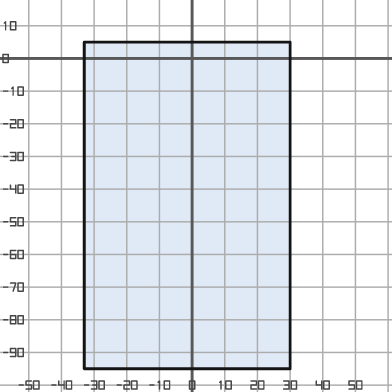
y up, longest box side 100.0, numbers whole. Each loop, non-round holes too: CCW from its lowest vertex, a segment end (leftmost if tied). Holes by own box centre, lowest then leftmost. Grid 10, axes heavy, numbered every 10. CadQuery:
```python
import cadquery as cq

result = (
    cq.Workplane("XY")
    .moveTo(-33.0, -95.0)
    .lineTo(30.0, -95.0)
    .lineTo(30.0, 5.0)
    .lineTo(-33.0, 5.0)
    .close()
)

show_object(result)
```